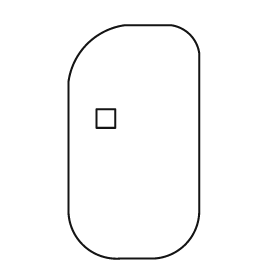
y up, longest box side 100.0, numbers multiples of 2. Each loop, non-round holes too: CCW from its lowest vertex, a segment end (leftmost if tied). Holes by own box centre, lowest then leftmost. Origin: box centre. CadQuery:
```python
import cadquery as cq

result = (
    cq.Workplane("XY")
    .moveTo(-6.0, -50.0)
    .lineTo(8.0, -50.0)
    .threePointArc((22.0, -44.0), (28.0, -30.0))
    .lineTo(28.0, 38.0)
    .threePointArc((24.0, 46.0), (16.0, 50.0))
    .lineTo(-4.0, 50.0)
    .threePointArc((-20.0, 42.0), (-28.0, 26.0))
    .lineTo(-28.0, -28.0)
    .threePointArc((-22.0, -44.0), (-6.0, -50.0))
    .close()
    .moveTo(-16.0, 6.0)
    .lineTo(-8.0, 6.0)
    .lineTo(-8.0, 14.0)
    .lineTo(-16.0, 14.0)
    .close()
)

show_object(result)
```